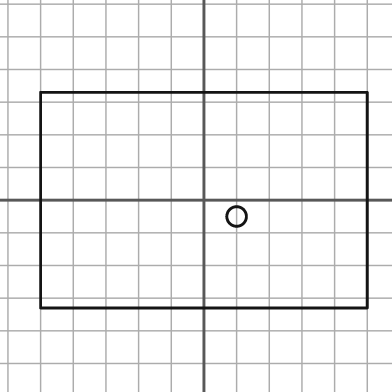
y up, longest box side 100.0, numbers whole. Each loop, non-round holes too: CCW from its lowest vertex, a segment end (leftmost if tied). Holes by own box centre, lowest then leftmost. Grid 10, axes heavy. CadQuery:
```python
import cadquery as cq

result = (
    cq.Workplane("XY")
    .moveTo(-50.0, -33.0)
    .lineTo(50.0, -33.0)
    .lineTo(50.0, 33.0)
    .lineTo(-50.0, 33.0)
    .close()
    .moveTo(10.0, -5.0)
    .circle(3.0)
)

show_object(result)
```